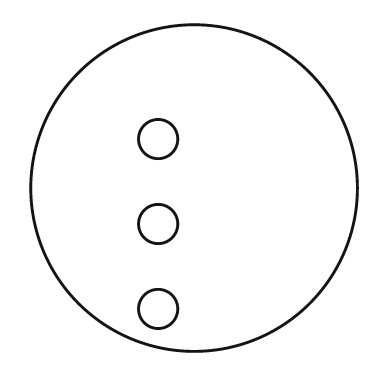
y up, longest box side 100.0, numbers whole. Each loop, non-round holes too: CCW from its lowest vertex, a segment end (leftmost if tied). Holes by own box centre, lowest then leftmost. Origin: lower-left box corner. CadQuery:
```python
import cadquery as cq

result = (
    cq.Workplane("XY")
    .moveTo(50.0, 50.0)
    .circle(50.0)
    .moveTo(39.0, 13.0)
    .circle(6.0)
    .moveTo(39.0, 39.0)
    .circle(6.0)
    .moveTo(39.0, 65.0)
    .circle(6.0)
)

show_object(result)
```